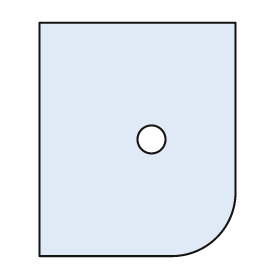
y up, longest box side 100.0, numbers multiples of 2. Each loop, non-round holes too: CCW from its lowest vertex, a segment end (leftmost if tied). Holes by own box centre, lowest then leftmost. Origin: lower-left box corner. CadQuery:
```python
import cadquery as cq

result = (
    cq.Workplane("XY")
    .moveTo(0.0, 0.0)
    .lineTo(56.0, 0.0)
    .threePointArc((76.0, 8.0), (84.0, 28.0))
    .lineTo(84.0, 100.0)
    .lineTo(0.0, 100.0)
    .close()
    .moveTo(48.0, 50.0)
    .circle(6.0)
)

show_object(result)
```